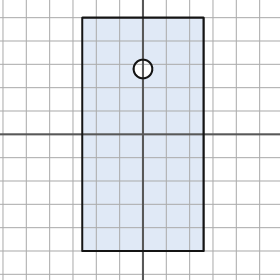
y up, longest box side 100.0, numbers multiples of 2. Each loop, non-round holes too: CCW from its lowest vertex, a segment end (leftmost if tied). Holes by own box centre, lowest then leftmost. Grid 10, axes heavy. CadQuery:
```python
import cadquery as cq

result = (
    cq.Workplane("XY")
    .moveTo(-26.0, -50.0)
    .lineTo(26.0, -50.0)
    .lineTo(26.0, 50.0)
    .lineTo(-26.0, 50.0)
    .close()
    .moveTo(0.0, 28.0)
    .circle(4.0)
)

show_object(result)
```